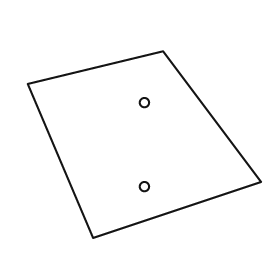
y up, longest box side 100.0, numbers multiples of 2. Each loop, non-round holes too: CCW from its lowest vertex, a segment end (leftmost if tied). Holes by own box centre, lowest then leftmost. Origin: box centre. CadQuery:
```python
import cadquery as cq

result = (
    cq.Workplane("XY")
    .moveTo(-22.0, -40.0)
    .lineTo(50.0, -16.0)
    .lineTo(8.0, 40.0)
    .lineTo(-50.0, 26.0)
    .close()
    .moveTo(0.0, -18.0)
    .circle(2.0)
    .moveTo(0.0, 18.0)
    .circle(2.0)
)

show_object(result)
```